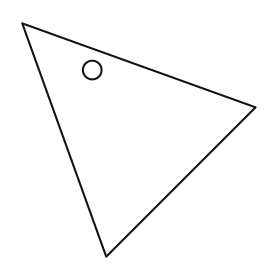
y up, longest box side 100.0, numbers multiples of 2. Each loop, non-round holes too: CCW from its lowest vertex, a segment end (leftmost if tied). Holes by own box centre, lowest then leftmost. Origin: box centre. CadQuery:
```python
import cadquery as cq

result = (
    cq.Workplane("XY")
    .moveTo(-14.0, -50.0)
    .lineTo(50.0, 14.0)
    .lineTo(-50.0, 50.0)
    .close()
    .moveTo(-20.0, 30.0)
    .circle(4.0)
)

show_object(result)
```